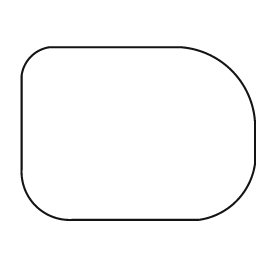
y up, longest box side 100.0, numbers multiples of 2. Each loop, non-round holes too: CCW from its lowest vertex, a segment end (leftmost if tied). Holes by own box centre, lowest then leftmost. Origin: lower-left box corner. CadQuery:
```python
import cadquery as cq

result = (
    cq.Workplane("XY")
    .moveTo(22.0, 0.0)
    .lineTo(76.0, 0.0)
    .threePointArc((92.0, 8.0), (100.0, 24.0))
    .lineTo(100.0, 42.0)
    .threePointArc((90.0, 64.0), (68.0, 74.0))
    .lineTo(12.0, 74.0)
    .threePointArc((4.0, 70.0), (0.0, 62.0))
    .lineTo(0.0, 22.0)
    .threePointArc((6.0, 6.0), (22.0, 0.0))
    .close()
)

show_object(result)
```